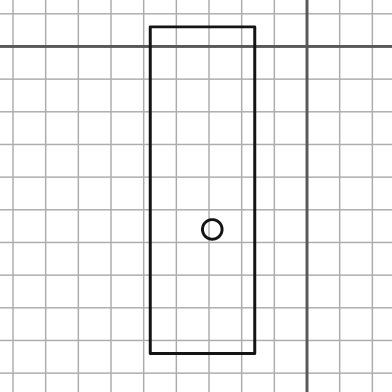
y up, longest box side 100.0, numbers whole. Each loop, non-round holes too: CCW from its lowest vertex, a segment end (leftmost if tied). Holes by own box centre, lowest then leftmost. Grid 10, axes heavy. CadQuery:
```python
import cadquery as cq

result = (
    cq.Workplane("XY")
    .moveTo(-48.0, -94.0)
    .lineTo(-16.0, -94.0)
    .lineTo(-16.0, 6.0)
    .lineTo(-48.0, 6.0)
    .close()
    .moveTo(-29.0, -56.0)
    .circle(3.0)
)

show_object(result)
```